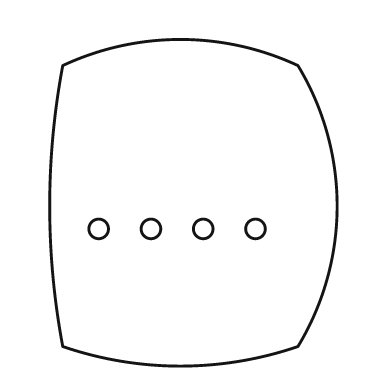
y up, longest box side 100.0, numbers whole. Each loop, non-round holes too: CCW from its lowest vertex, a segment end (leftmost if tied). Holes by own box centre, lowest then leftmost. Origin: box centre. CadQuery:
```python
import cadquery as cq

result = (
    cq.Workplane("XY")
    .moveTo(-40.0, -44.0)
    .threePointArc((-4.0, -50.0), (32.0, -44.0))
    .threePointArc((44.0, -1.0), (32.0, 42.0))
    .threePointArc((-4.0, 50.0), (-40.0, 42.0))
    .threePointArc((-44.0, -1.0), (-40.0, -44.0))
    .close()
    .moveTo(-29.0, -8.0)
    .circle(3.0)
    .moveTo(-13.0, -8.0)
    .circle(3.0)
    .moveTo(3.0, -8.0)
    .circle(3.0)
    .moveTo(19.0, -8.0)
    .circle(3.0)
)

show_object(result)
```